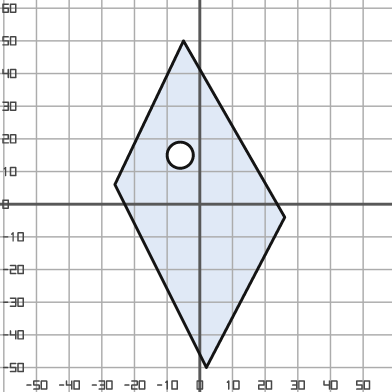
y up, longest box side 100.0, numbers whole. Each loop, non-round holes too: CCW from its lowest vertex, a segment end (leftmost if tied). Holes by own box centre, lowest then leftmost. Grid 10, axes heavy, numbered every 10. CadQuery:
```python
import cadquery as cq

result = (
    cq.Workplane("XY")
    .moveTo(2.0, -50.0)
    .lineTo(26.0, -4.0)
    .lineTo(-5.0, 50.0)
    .lineTo(-26.0, 6.0)
    .close()
    .moveTo(-6.0, 15.0)
    .circle(4.0)
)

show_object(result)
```